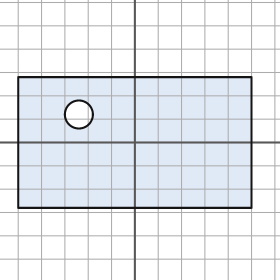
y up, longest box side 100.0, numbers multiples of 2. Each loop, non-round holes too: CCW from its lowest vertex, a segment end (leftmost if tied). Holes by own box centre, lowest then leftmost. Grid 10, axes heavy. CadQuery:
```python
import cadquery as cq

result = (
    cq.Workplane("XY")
    .moveTo(-50.0, -28.0)
    .lineTo(50.0, -28.0)
    .lineTo(50.0, 28.0)
    .lineTo(-50.0, 28.0)
    .close()
    .moveTo(-24.0, 12.0)
    .circle(6.0)
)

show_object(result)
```